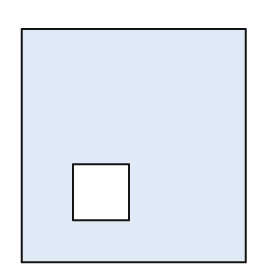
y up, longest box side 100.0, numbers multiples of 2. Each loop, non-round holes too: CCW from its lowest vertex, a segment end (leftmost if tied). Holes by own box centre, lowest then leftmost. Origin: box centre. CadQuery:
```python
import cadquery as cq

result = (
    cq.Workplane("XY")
    .moveTo(-48.0, -50.0)
    .lineTo(48.0, -50.0)
    .lineTo(48.0, 50.0)
    .lineTo(-48.0, 50.0)
    .close()
    .moveTo(-26.0, -32.0)
    .lineTo(-2.0, -32.0)
    .lineTo(-2.0, -8.0)
    .lineTo(-26.0, -8.0)
    .close()
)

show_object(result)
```